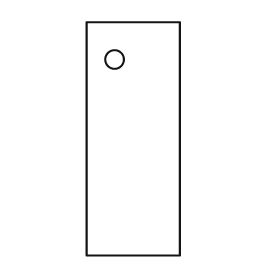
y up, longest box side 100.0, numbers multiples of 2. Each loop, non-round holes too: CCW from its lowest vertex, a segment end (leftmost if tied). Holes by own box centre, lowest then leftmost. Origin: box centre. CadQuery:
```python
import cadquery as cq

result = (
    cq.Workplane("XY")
    .moveTo(-20.0, -50.0)
    .lineTo(20.0, -50.0)
    .lineTo(20.0, 50.0)
    .lineTo(-20.0, 50.0)
    .close()
    .moveTo(-8.0, 34.0)
    .circle(4.0)
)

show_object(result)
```